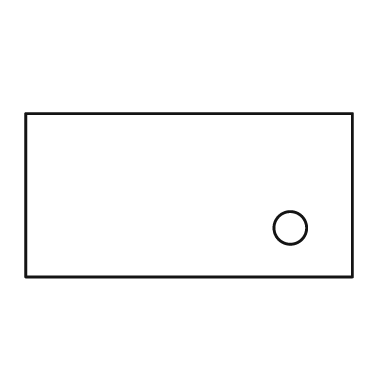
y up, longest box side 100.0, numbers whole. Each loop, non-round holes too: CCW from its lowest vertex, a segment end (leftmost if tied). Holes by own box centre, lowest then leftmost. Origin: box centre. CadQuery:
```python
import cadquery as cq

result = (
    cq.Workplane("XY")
    .moveTo(-50.0, -25.0)
    .lineTo(50.0, -25.0)
    .lineTo(50.0, 25.0)
    .lineTo(-50.0, 25.0)
    .close()
    .moveTo(31.0, -10.0)
    .circle(5.0)
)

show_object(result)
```